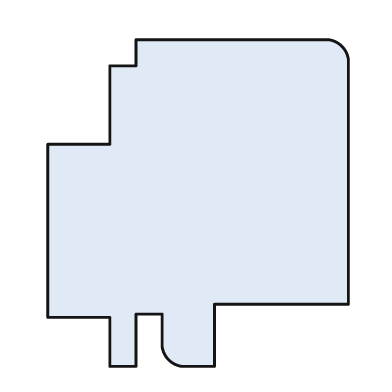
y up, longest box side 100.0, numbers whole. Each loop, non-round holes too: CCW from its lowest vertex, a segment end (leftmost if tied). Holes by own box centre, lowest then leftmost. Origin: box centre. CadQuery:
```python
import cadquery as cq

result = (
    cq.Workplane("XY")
    .moveTo(-27.0, -50.0)
    .lineTo(-19.0, -50.0)
    .lineTo(-19.0, -34.0)
    .lineTo(-11.0, -34.0)
    .lineTo(-11.0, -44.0)
    .threePointArc((-9.0, -48.0), (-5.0, -50.0))
    .lineTo(5.0, -50.0)
    .lineTo(5.0, -31.0)
    .lineTo(46.0, -31.0)
    .lineTo(46.0, 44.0)
    .threePointArc((44.0, 48.0), (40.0, 50.0))
    .lineTo(-19.0, 50.0)
    .lineTo(-19.0, 42.0)
    .lineTo(-27.0, 42.0)
    .lineTo(-27.0, 18.0)
    .lineTo(-46.0, 18.0)
    .lineTo(-46.0, -35.0)
    .lineTo(-27.0, -35.0)
    .close()
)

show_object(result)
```